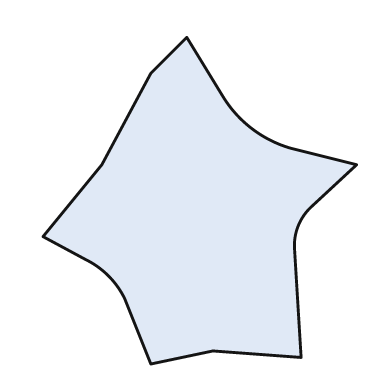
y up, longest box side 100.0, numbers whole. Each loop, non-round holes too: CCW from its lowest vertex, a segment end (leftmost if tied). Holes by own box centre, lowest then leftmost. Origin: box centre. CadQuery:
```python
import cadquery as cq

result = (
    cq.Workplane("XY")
    .moveTo(-15.0, -50.0)
    .lineTo(4.0, -46.0)
    .lineTo(31.0, -48.0)
    .lineTo(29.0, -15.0)
    .threePointArc((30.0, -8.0), (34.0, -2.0))
    .lineTo(48.0, 11.0)
    .lineTo(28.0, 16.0)
    .threePointArc((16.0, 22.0), (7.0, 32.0))
    .lineTo(-4.0, 50.0)
    .lineTo(-15.0, 39.0)
    .lineTo(-30.0, 11.0)
    .lineTo(-48.0, -11.0)
    .lineTo(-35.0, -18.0)
    .threePointArc((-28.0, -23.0), (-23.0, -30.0))
    .close()
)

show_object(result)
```